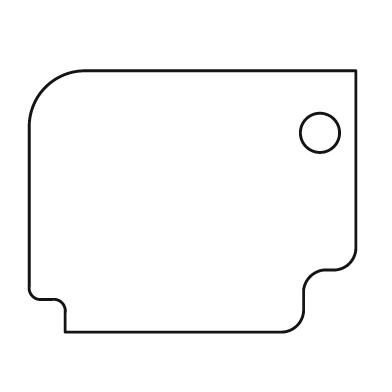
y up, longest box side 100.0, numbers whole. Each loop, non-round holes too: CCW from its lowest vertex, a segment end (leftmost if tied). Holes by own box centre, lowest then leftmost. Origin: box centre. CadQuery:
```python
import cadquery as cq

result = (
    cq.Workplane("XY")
    .moveTo(-39.0, -40.0)
    .lineTo(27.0, -40.0)
    .threePointArc((32.0, -38.0), (34.0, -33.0))
    .lineTo(34.0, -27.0)
    .threePointArc((36.0, -23.0), (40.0, -21.0))
    .lineTo(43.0, -21.0)
    .threePointArc((48.0, -19.0), (50.0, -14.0))
    .lineTo(50.0, 40.0)
    .lineTo(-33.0, 40.0)
    .threePointArc((-45.0, 35.0), (-50.0, 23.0))
    .lineTo(-50.0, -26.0)
    .threePointArc((-49.0, -29.0), (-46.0, -30.0))
    .lineTo(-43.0, -30.0)
    .threePointArc((-40.0, -31.0), (-39.0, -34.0))
    .close()
    .moveTo(39.0, 21.0)
    .circle(6.0)
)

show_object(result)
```